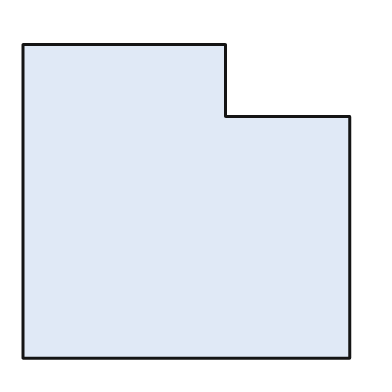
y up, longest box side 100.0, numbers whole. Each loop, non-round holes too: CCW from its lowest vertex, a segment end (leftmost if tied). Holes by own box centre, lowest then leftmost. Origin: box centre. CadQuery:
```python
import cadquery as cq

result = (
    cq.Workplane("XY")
    .moveTo(-50.0, -48.0)
    .lineTo(50.0, -48.0)
    .lineTo(50.0, 26.0)
    .lineTo(12.0, 26.0)
    .lineTo(12.0, 48.0)
    .lineTo(-50.0, 48.0)
    .close()
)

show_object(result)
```